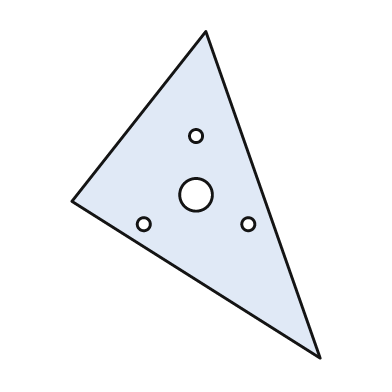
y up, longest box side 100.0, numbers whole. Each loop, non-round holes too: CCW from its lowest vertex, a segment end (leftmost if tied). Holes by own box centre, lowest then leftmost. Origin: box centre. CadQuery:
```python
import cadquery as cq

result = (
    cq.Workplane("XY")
    .moveTo(38.0, -50.0)
    .lineTo(3.0, 50.0)
    .lineTo(-38.0, -2.0)
    .close()
    .moveTo(-16.0, -9.0)
    .circle(2.0)
    .moveTo(16.0, -9.0)
    .circle(2.0)
    .moveTo(0.0, 0.0)
    .circle(5.0)
    .moveTo(0.0, 18.0)
    .circle(2.0)
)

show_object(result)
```